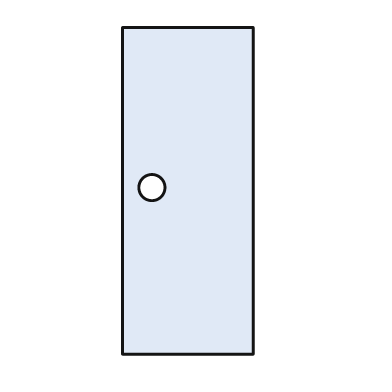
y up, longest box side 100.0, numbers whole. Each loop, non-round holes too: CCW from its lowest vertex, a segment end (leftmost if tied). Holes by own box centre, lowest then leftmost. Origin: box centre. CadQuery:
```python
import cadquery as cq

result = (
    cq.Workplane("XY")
    .moveTo(-20.0, -50.0)
    .lineTo(20.0, -50.0)
    .lineTo(20.0, 50.0)
    .lineTo(-20.0, 50.0)
    .close()
    .moveTo(-11.0, 1.0)
    .circle(4.0)
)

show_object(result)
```